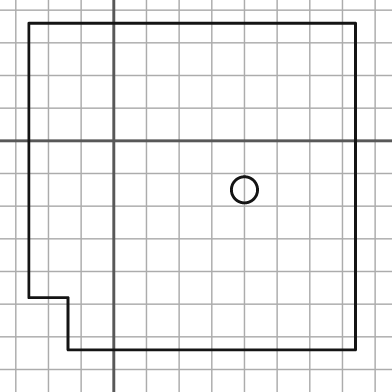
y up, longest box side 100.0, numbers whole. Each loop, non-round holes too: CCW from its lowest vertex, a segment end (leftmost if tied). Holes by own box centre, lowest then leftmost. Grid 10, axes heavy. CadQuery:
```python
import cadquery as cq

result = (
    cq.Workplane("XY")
    .moveTo(-14.0, -64.0)
    .lineTo(74.0, -64.0)
    .lineTo(74.0, 36.0)
    .lineTo(-26.0, 36.0)
    .lineTo(-26.0, -48.0)
    .lineTo(-14.0, -48.0)
    .close()
    .moveTo(40.0, -15.0)
    .circle(4.0)
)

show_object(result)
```